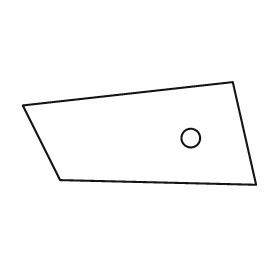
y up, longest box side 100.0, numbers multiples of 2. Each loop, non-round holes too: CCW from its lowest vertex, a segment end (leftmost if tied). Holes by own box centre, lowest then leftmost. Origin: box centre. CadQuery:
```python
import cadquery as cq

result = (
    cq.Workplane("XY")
    .moveTo(50.0, -22.0)
    .lineTo(40.0, 22.0)
    .lineTo(-50.0, 12.0)
    .lineTo(-34.0, -20.0)
    .close()
    .moveTo(22.0, -2.0)
    .circle(4.0)
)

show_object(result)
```